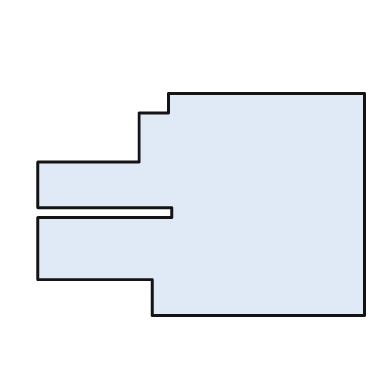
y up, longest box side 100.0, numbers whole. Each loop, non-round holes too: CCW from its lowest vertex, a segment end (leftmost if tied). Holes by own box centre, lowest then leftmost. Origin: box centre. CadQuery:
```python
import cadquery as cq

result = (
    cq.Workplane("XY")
    .moveTo(-15.0, -34.0)
    .lineTo(50.0, -34.0)
    .lineTo(50.0, 34.0)
    .lineTo(-10.0, 34.0)
    .lineTo(-10.0, 28.0)
    .lineTo(-19.0, 28.0)
    .lineTo(-19.0, 13.0)
    .lineTo(-50.0, 13.0)
    .lineTo(-50.0, -1.0)
    .lineTo(-9.0, -1.0)
    .lineTo(-9.0, -4.0)
    .lineTo(-50.0, -4.0)
    .lineTo(-50.0, -23.0)
    .lineTo(-15.0, -23.0)
    .close()
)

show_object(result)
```